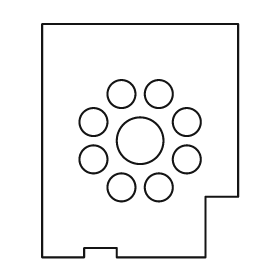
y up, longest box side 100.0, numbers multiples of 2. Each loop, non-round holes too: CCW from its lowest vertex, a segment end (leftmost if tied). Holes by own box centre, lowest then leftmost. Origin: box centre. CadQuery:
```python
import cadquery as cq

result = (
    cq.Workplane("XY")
    .moveTo(-42.0, -50.0)
    .lineTo(-24.0, -50.0)
    .lineTo(-24.0, -46.0)
    .lineTo(-10.0, -46.0)
    .lineTo(-10.0, -50.0)
    .lineTo(28.0, -50.0)
    .lineTo(28.0, -24.0)
    .lineTo(42.0, -24.0)
    .lineTo(42.0, 50.0)
    .lineTo(-42.0, 50.0)
    .close()
    .moveTo(-8.0, -20.0)
    .circle(6.0)
    .moveTo(8.0, -20.0)
    .circle(6.0)
    .moveTo(-20.0, -8.0)
    .circle(6.0)
    .moveTo(20.0, -8.0)
    .circle(6.0)
    .moveTo(0.0, 0.0)
    .circle(10.0)
    .moveTo(-20.0, 8.0)
    .circle(6.0)
    .moveTo(20.0, 8.0)
    .circle(6.0)
    .moveTo(-8.0, 20.0)
    .circle(6.0)
    .moveTo(8.0, 20.0)
    .circle(6.0)
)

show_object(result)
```